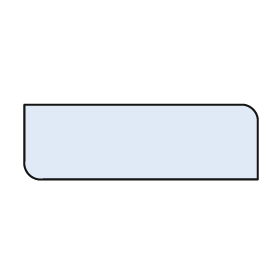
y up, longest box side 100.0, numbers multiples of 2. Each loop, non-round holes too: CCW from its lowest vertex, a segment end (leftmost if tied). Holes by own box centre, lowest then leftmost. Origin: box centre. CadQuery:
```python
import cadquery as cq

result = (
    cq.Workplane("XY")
    .moveTo(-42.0, -16.0)
    .lineTo(50.0, -16.0)
    .lineTo(50.0, 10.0)
    .threePointArc((48.0, 14.0), (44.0, 16.0))
    .lineTo(-50.0, 16.0)
    .lineTo(-50.0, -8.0)
    .threePointArc((-48.0, -14.0), (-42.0, -16.0))
    .close()
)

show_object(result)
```